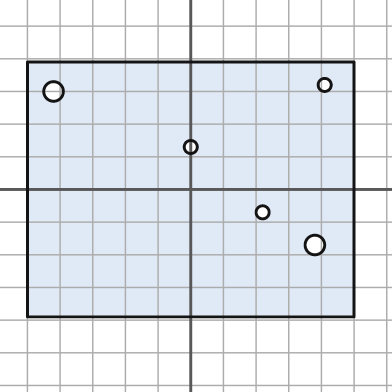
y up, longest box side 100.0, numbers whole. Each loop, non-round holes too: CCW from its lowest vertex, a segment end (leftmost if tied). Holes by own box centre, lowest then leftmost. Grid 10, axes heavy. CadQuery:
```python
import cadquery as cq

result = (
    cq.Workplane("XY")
    .moveTo(-50.0, -39.0)
    .lineTo(50.0, -39.0)
    .lineTo(50.0, 39.0)
    .lineTo(-50.0, 39.0)
    .close()
    .moveTo(38.0, -17.0)
    .circle(3.0)
    .moveTo(22.0, -7.0)
    .circle(2.0)
    .moveTo(0.0, 13.0)
    .circle(2.0)
    .moveTo(-42.0, 30.0)
    .circle(3.0)
    .moveTo(41.0, 32.0)
    .circle(2.0)
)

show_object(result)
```